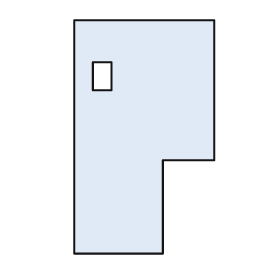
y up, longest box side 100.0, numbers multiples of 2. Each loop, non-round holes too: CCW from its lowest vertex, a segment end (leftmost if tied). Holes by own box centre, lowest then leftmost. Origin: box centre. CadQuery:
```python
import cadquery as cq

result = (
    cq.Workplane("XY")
    .moveTo(-30.0, -50.0)
    .lineTo(8.0, -50.0)
    .lineTo(8.0, -10.0)
    .lineTo(30.0, -10.0)
    .lineTo(30.0, 50.0)
    .lineTo(-30.0, 50.0)
    .close()
    .moveTo(-22.0, 20.0)
    .lineTo(-14.0, 20.0)
    .lineTo(-14.0, 32.0)
    .lineTo(-22.0, 32.0)
    .close()
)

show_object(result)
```